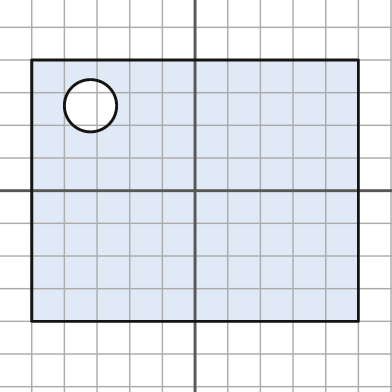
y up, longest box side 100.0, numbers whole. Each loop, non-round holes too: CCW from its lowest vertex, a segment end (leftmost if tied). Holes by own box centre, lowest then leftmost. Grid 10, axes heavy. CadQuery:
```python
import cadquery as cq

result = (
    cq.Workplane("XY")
    .moveTo(-50.0, -40.0)
    .lineTo(50.0, -40.0)
    .lineTo(50.0, 40.0)
    .lineTo(-50.0, 40.0)
    .close()
    .moveTo(-32.0, 26.0)
    .circle(8.0)
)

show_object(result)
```